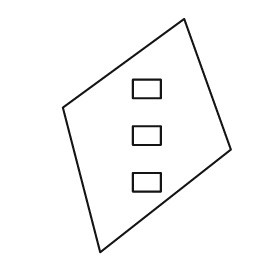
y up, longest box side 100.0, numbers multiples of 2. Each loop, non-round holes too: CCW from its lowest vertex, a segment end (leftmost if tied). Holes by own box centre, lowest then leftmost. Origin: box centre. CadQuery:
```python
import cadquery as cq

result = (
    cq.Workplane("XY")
    .moveTo(-20.0, -50.0)
    .lineTo(36.0, -6.0)
    .lineTo(16.0, 50.0)
    .lineTo(-36.0, 12.0)
    .close()
    .moveTo(-6.0, -24.0)
    .lineTo(6.0, -24.0)
    .lineTo(6.0, -16.0)
    .lineTo(-6.0, -16.0)
    .close()
    .moveTo(-6.0, -4.0)
    .lineTo(6.0, -4.0)
    .lineTo(6.0, 4.0)
    .lineTo(-6.0, 4.0)
    .close()
    .moveTo(-6.0, 16.0)
    .lineTo(6.0, 16.0)
    .lineTo(6.0, 24.0)
    .lineTo(-6.0, 24.0)
    .close()
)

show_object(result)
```